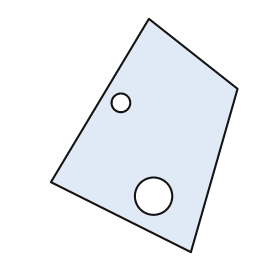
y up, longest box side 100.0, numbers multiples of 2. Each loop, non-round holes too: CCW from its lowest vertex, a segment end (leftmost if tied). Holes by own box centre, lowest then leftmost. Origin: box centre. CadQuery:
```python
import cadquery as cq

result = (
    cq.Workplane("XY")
    .moveTo(20.0, -50.0)
    .lineTo(40.0, 20.0)
    .lineTo(2.0, 50.0)
    .lineTo(-40.0, -20.0)
    .close()
    .moveTo(4.0, -26.0)
    .circle(8.0)
    .moveTo(-10.0, 14.0)
    .circle(4.0)
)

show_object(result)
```